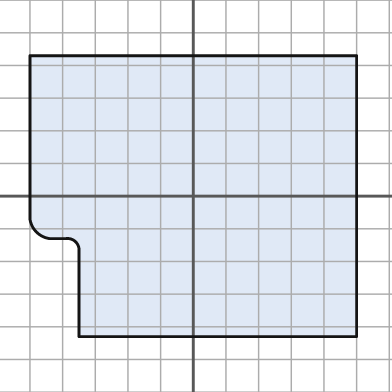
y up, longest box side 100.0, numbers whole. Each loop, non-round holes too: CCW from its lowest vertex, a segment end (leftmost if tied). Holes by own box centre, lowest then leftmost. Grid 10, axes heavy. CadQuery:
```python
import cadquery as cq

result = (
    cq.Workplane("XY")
    .moveTo(-35.0, -43.0)
    .lineTo(50.0, -43.0)
    .lineTo(50.0, 43.0)
    .lineTo(-50.0, 43.0)
    .lineTo(-50.0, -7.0)
    .threePointArc((-48.0, -11.0), (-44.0, -13.0))
    .lineTo(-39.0, -13.0)
    .threePointArc((-36.0, -14.0), (-35.0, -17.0))
    .close()
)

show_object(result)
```